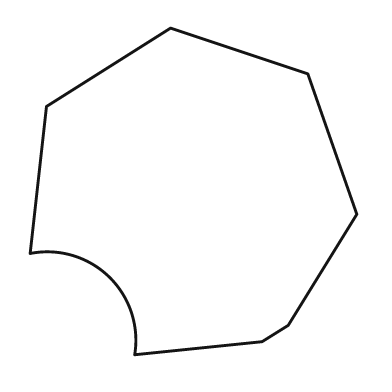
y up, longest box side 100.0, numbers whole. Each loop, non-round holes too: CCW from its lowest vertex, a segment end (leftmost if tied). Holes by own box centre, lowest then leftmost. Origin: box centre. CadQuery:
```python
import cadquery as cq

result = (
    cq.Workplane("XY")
    .moveTo(-18.0, -50.0)
    .lineTo(21.0, -46.0)
    .lineTo(29.0, -41.0)
    .lineTo(50.0, -7.0)
    .lineTo(35.0, 36.0)
    .lineTo(-7.0, 50.0)
    .lineTo(-45.0, 26.0)
    .lineTo(-50.0, -19.0)
    .threePointArc((-26.0, -26.0), (-18.0, -50.0))
    .close()
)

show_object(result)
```